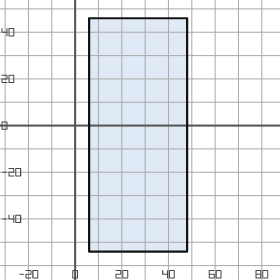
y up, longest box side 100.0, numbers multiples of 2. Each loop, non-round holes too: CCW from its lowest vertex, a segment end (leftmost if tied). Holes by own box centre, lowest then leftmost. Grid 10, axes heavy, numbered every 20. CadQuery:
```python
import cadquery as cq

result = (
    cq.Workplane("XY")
    .moveTo(6.0, -54.0)
    .lineTo(48.0, -54.0)
    .lineTo(48.0, 46.0)
    .lineTo(6.0, 46.0)
    .close()
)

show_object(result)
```